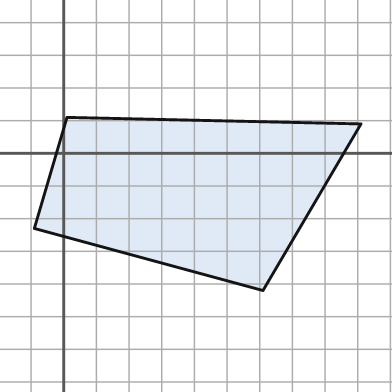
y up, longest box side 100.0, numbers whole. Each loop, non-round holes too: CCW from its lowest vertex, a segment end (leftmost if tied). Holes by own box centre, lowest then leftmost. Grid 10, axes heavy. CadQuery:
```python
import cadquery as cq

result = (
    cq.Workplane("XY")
    .moveTo(61.0, -42.0)
    .lineTo(91.0, 9.0)
    .lineTo(1.0, 11.0)
    .lineTo(-9.0, -23.0)
    .close()
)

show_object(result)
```